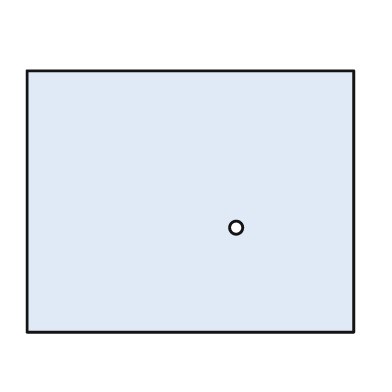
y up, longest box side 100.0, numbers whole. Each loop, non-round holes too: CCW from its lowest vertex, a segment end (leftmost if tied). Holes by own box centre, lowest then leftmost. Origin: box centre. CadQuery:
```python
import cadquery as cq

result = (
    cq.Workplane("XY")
    .moveTo(-50.0, -40.0)
    .lineTo(50.0, -40.0)
    .lineTo(50.0, 40.0)
    .lineTo(-50.0, 40.0)
    .close()
    .moveTo(14.0, -8.0)
    .circle(2.0)
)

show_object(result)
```